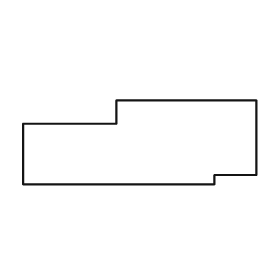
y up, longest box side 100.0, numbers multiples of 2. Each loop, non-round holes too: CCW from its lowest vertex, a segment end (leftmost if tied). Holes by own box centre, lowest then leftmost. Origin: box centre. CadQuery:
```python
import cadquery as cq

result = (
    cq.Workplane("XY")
    .moveTo(-50.0, -18.0)
    .lineTo(32.0, -18.0)
    .lineTo(32.0, -14.0)
    .lineTo(50.0, -14.0)
    .lineTo(50.0, 18.0)
    .lineTo(-10.0, 18.0)
    .lineTo(-10.0, 8.0)
    .lineTo(-50.0, 8.0)
    .close()
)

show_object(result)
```